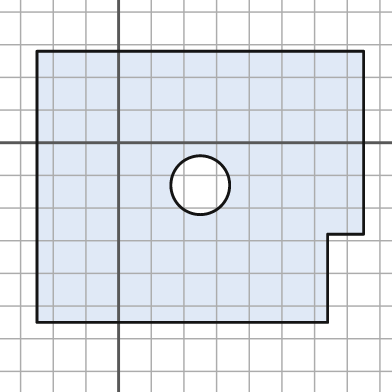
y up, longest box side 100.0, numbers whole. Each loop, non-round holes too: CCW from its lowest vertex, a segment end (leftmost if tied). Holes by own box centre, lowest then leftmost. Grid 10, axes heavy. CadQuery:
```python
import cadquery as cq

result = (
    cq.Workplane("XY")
    .moveTo(-25.0, -55.0)
    .lineTo(64.0, -55.0)
    .lineTo(64.0, -28.0)
    .lineTo(75.0, -28.0)
    .lineTo(75.0, 28.0)
    .lineTo(-25.0, 28.0)
    .close()
    .moveTo(25.0, -13.0)
    .circle(9.0)
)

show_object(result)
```